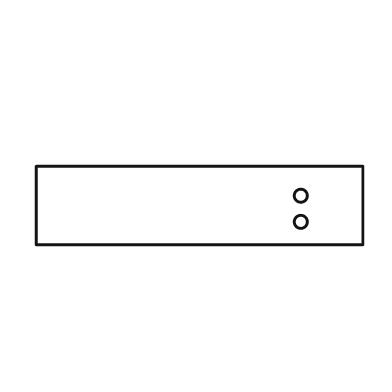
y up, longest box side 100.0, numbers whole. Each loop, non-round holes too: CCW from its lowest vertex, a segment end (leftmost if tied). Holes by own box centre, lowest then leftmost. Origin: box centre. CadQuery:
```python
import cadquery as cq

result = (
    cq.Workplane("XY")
    .moveTo(-50.0, -12.0)
    .lineTo(50.0, -12.0)
    .lineTo(50.0, 12.0)
    .lineTo(-50.0, 12.0)
    .close()
    .moveTo(31.0, -5.0)
    .circle(2.0)
    .moveTo(31.0, 3.0)
    .circle(2.0)
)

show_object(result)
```